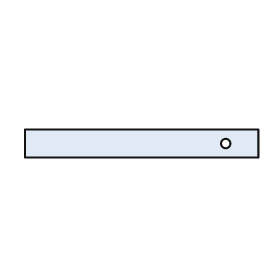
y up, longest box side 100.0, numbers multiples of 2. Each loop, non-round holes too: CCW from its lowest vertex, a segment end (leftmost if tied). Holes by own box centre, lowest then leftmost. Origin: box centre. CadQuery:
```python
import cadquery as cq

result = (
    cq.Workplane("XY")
    .moveTo(-50.0, -6.0)
    .lineTo(50.0, -6.0)
    .lineTo(50.0, 6.0)
    .lineTo(-50.0, 6.0)
    .close()
    .moveTo(36.0, 0.0)
    .circle(2.0)
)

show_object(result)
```